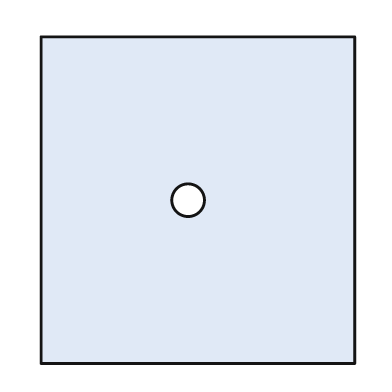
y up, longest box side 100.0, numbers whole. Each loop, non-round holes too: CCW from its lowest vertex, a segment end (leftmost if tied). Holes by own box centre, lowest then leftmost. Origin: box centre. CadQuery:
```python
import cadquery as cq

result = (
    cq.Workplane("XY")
    .moveTo(-48.0, -50.0)
    .lineTo(48.0, -50.0)
    .lineTo(48.0, 50.0)
    .lineTo(-48.0, 50.0)
    .close()
    .moveTo(-3.0, 0.0)
    .circle(5.0)
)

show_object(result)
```